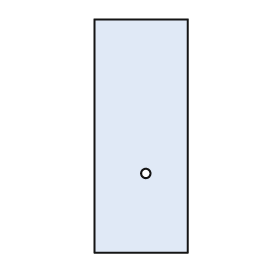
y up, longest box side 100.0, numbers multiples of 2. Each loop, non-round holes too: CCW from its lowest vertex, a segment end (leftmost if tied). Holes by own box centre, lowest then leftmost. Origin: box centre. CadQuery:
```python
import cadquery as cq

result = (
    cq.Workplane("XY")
    .moveTo(-20.0, -50.0)
    .lineTo(20.0, -50.0)
    .lineTo(20.0, 50.0)
    .lineTo(-20.0, 50.0)
    .close()
    .moveTo(2.0, -16.0)
    .circle(2.0)
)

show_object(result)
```